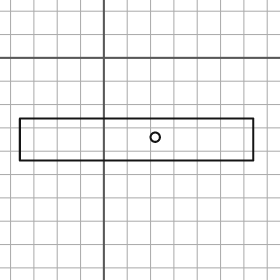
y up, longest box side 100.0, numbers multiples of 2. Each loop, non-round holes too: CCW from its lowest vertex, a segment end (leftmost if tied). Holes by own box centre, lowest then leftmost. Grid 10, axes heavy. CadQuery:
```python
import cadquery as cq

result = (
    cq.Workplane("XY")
    .moveTo(-36.0, -44.0)
    .lineTo(64.0, -44.0)
    .lineTo(64.0, -26.0)
    .lineTo(-36.0, -26.0)
    .close()
    .moveTo(22.0, -34.0)
    .circle(2.0)
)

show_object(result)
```